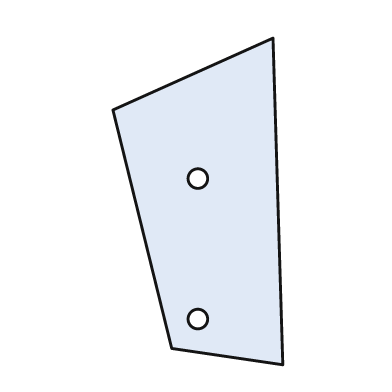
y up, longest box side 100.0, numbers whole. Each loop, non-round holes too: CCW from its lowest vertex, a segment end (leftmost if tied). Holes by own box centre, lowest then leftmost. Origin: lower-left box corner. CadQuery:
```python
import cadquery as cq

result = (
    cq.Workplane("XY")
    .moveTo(52.0, 0.0)
    .lineTo(49.0, 100.0)
    .lineTo(0.0, 78.0)
    .lineTo(18.0, 5.0)
    .close()
    .moveTo(26.0, 14.0)
    .circle(3.0)
    .moveTo(26.0, 57.0)
    .circle(3.0)
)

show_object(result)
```